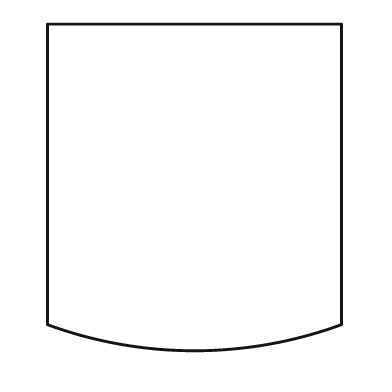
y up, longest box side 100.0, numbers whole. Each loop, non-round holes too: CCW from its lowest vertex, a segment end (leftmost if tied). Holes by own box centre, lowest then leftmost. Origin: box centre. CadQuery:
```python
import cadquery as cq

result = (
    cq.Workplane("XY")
    .moveTo(-45.0, -42.0)
    .threePointArc((0.0, -50.0), (45.0, -42.0))
    .lineTo(45.0, 50.0)
    .lineTo(-45.0, 50.0)
    .close()
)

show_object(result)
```